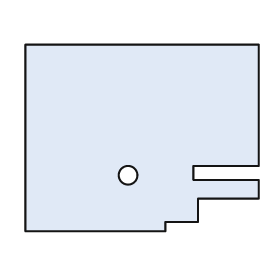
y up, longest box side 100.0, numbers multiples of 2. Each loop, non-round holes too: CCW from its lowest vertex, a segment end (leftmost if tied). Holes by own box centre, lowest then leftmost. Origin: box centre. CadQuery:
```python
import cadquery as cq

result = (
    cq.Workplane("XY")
    .moveTo(-50.0, -40.0)
    .lineTo(10.0, -40.0)
    .lineTo(10.0, -36.0)
    .lineTo(24.0, -36.0)
    .lineTo(24.0, -26.0)
    .lineTo(50.0, -26.0)
    .lineTo(50.0, -18.0)
    .lineTo(22.0, -18.0)
    .lineTo(22.0, -12.0)
    .lineTo(50.0, -12.0)
    .lineTo(50.0, 40.0)
    .lineTo(-50.0, 40.0)
    .close()
    .moveTo(-6.0, -16.0)
    .circle(4.0)
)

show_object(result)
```